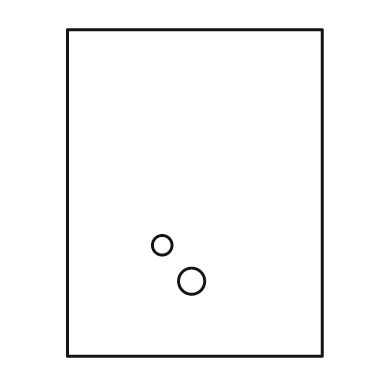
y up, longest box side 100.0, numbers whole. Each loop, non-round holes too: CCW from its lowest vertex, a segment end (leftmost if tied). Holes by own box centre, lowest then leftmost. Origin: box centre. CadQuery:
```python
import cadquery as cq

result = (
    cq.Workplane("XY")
    .moveTo(-39.0, -50.0)
    .lineTo(39.0, -50.0)
    .lineTo(39.0, 50.0)
    .lineTo(-39.0, 50.0)
    .close()
    .moveTo(-1.0, -27.0)
    .circle(4.0)
    .moveTo(-10.0, -16.0)
    .circle(3.0)
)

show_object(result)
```